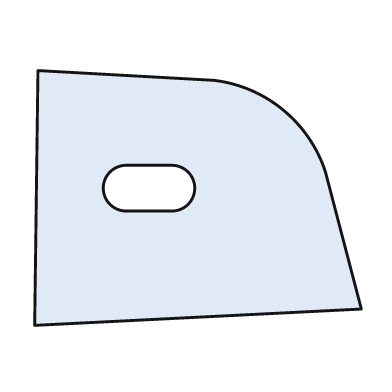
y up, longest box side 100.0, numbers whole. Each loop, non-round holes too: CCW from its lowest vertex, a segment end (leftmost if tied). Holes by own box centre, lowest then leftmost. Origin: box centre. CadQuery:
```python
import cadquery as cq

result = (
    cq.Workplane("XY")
    .moveTo(-50.0, -39.0)
    .lineTo(50.0, -34.0)
    .lineTo(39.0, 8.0)
    .threePointArc((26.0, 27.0), (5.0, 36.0))
    .lineTo(-49.0, 39.0)
    .close()
    .moveTo(-22.0, -4.0)
    .lineTo(-8.0, -4.0)
    .threePointArc((-1.0, 3.0), (-8.0, 10.0))
    .lineTo(-22.0, 10.0)
    .threePointArc((-29.0, 3.0), (-22.0, -4.0))
    .close()
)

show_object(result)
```